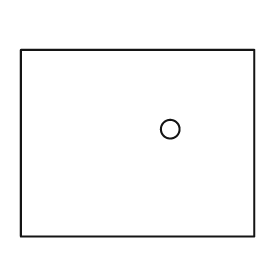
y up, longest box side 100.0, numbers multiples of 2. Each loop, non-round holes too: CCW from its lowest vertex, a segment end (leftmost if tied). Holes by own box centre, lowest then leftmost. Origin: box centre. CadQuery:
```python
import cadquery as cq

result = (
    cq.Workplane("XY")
    .moveTo(-50.0, -40.0)
    .lineTo(50.0, -40.0)
    .lineTo(50.0, 40.0)
    .lineTo(-50.0, 40.0)
    .close()
    .moveTo(14.0, 6.0)
    .circle(4.0)
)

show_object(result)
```